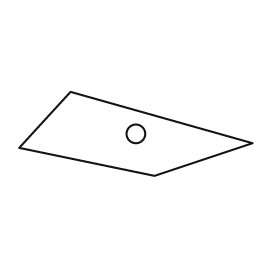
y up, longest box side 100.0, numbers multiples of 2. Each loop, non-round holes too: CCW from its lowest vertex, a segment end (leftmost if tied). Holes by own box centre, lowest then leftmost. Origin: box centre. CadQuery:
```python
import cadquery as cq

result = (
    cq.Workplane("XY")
    .moveTo(8.0, -18.0)
    .lineTo(50.0, -4.0)
    .lineTo(-28.0, 18.0)
    .lineTo(-50.0, -6.0)
    .close()
    .moveTo(0.0, 0.0)
    .circle(4.0)
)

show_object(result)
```